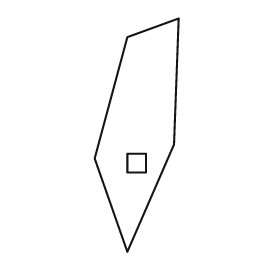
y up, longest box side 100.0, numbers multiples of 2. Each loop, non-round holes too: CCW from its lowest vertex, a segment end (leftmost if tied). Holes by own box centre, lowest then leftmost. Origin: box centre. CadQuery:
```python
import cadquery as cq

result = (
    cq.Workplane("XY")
    .moveTo(-4.0, -50.0)
    .lineTo(16.0, -4.0)
    .lineTo(18.0, 50.0)
    .lineTo(-4.0, 42.0)
    .lineTo(-18.0, -10.0)
    .close()
    .moveTo(-4.0, -16.0)
    .lineTo(4.0, -16.0)
    .lineTo(4.0, -8.0)
    .lineTo(-4.0, -8.0)
    .close()
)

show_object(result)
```